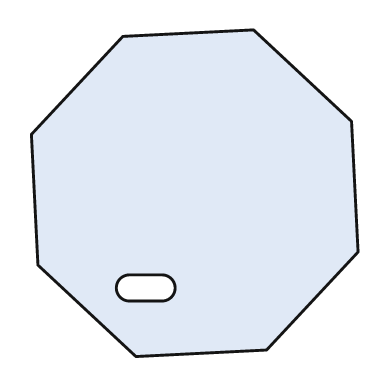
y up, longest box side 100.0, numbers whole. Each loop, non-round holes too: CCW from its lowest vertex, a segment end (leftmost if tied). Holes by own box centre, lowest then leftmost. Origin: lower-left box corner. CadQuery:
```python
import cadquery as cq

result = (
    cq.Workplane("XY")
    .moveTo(32.0, 0.0)
    .lineTo(72.0, 2.0)
    .lineTo(100.0, 32.0)
    .lineTo(98.0, 72.0)
    .lineTo(68.0, 100.0)
    .lineTo(28.0, 98.0)
    .lineTo(0.0, 68.0)
    .lineTo(2.0, 28.0)
    .close()
    .moveTo(30.0, 17.0)
    .lineTo(40.0, 17.0)
    .threePointArc((44.0, 21.0), (40.0, 25.0))
    .lineTo(30.0, 25.0)
    .threePointArc((26.0, 21.0), (30.0, 17.0))
    .close()
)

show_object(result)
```